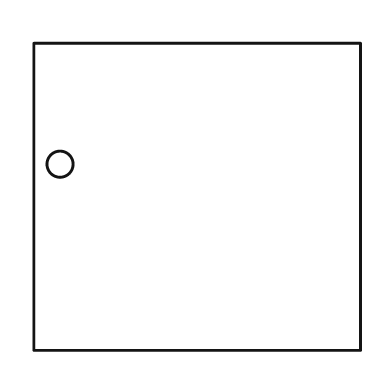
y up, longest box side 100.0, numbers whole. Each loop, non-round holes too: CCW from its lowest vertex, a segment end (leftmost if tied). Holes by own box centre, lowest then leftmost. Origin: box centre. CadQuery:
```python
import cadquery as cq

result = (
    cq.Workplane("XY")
    .moveTo(-50.0, -47.0)
    .lineTo(50.0, -47.0)
    .lineTo(50.0, 47.0)
    .lineTo(-50.0, 47.0)
    .close()
    .moveTo(-42.0, 10.0)
    .circle(4.0)
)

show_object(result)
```